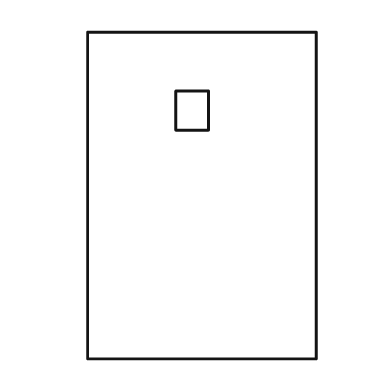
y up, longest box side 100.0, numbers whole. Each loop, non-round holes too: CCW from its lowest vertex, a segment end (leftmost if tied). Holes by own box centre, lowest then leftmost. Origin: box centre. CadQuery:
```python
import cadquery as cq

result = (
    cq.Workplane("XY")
    .moveTo(-35.0, -50.0)
    .lineTo(35.0, -50.0)
    .lineTo(35.0, 50.0)
    .lineTo(-35.0, 50.0)
    .close()
    .moveTo(-8.0, 20.0)
    .lineTo(2.0, 20.0)
    .lineTo(2.0, 32.0)
    .lineTo(-8.0, 32.0)
    .close()
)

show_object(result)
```